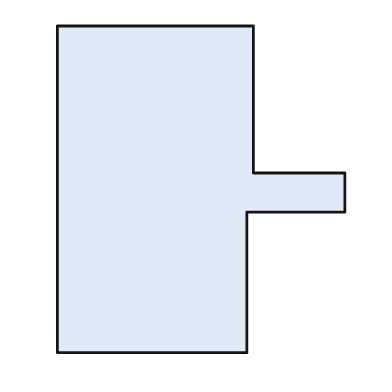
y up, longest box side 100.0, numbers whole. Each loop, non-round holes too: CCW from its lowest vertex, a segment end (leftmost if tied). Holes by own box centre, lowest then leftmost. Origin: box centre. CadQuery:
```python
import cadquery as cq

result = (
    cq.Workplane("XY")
    .moveTo(-44.0, -50.0)
    .lineTo(14.0, -50.0)
    .lineTo(14.0, -7.0)
    .lineTo(44.0, -7.0)
    .lineTo(44.0, 5.0)
    .lineTo(16.0, 5.0)
    .lineTo(16.0, 50.0)
    .lineTo(-44.0, 50.0)
    .close()
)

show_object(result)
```